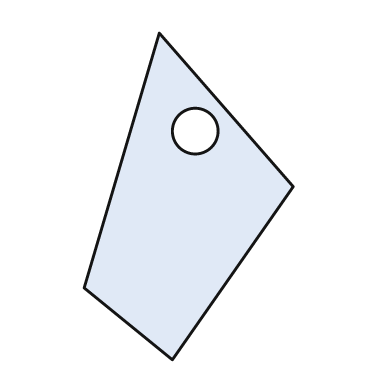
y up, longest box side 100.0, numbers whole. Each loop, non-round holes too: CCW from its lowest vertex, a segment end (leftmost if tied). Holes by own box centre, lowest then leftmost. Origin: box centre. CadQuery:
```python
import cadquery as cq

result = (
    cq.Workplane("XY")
    .moveTo(-5.0, -50.0)
    .lineTo(32.0, 3.0)
    .lineTo(-9.0, 50.0)
    .lineTo(-32.0, -28.0)
    .close()
    .moveTo(2.0, 20.0)
    .circle(7.0)
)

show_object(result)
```